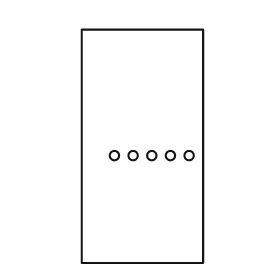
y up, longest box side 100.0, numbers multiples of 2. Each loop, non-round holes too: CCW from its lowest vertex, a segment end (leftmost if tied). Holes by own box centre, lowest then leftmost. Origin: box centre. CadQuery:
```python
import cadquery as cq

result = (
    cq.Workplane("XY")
    .moveTo(-26.0, -50.0)
    .lineTo(26.0, -50.0)
    .lineTo(26.0, 50.0)
    .lineTo(-26.0, 50.0)
    .close()
    .moveTo(-12.0, -4.0)
    .circle(2.0)
    .moveTo(-4.0, -4.0)
    .circle(2.0)
    .moveTo(4.0, -4.0)
    .circle(2.0)
    .moveTo(12.0, -4.0)
    .circle(2.0)
    .moveTo(20.0, -4.0)
    .circle(2.0)
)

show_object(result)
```